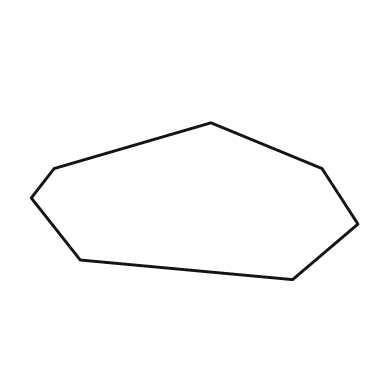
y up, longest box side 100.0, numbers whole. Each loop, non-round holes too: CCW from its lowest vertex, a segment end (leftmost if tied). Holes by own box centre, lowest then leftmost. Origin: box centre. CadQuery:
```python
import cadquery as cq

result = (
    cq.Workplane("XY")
    .moveTo(30.0, -24.0)
    .lineTo(50.0, -7.0)
    .lineTo(39.0, 10.0)
    .lineTo(5.0, 24.0)
    .lineTo(-43.0, 10.0)
    .lineTo(-50.0, 1.0)
    .lineTo(-35.0, -18.0)
    .close()
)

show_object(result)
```